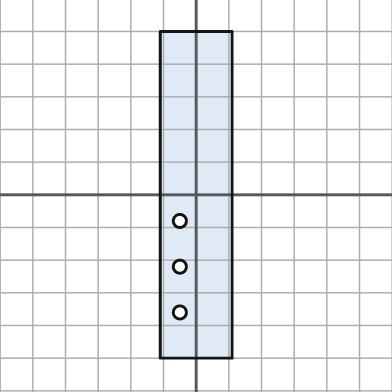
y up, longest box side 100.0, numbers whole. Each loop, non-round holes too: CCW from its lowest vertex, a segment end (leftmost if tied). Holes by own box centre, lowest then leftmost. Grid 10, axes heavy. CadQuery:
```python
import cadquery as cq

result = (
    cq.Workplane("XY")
    .moveTo(-11.0, -50.0)
    .lineTo(11.0, -50.0)
    .lineTo(11.0, 50.0)
    .lineTo(-11.0, 50.0)
    .close()
    .moveTo(-5.0, -36.0)
    .circle(2.0)
    .moveTo(-5.0, -22.0)
    .circle(2.0)
    .moveTo(-5.0, -8.0)
    .circle(2.0)
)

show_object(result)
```